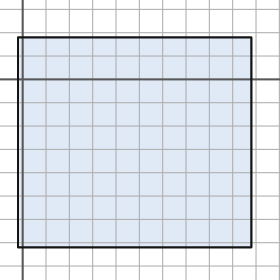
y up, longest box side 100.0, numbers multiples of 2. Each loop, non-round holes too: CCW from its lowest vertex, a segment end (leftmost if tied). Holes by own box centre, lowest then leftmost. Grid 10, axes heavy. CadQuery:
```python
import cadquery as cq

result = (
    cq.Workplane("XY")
    .moveTo(-2.0, -72.0)
    .lineTo(98.0, -72.0)
    .lineTo(98.0, 18.0)
    .lineTo(-2.0, 18.0)
    .close()
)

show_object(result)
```